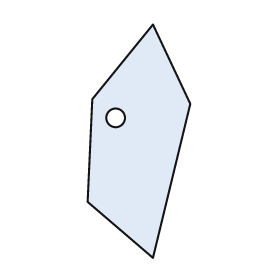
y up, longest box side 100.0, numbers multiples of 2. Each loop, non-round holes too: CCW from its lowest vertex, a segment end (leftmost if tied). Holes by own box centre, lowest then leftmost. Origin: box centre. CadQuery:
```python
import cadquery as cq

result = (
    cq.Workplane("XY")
    .moveTo(6.0, -50.0)
    .lineTo(22.0, 16.0)
    .lineTo(6.0, 50.0)
    .lineTo(-20.0, 18.0)
    .lineTo(-22.0, -26.0)
    .close()
    .moveTo(-10.0, 10.0)
    .circle(4.0)
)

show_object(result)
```